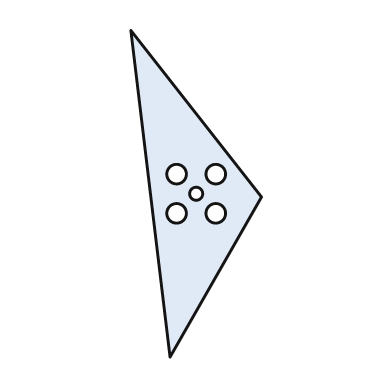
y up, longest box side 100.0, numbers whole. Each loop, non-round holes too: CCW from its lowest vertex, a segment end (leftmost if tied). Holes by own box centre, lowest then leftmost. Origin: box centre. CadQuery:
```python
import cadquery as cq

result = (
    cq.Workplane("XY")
    .moveTo(-8.0, -50.0)
    .lineTo(20.0, -1.0)
    .lineTo(-20.0, 50.0)
    .close()
    .moveTo(-6.0, -6.0)
    .circle(3.0)
    .moveTo(6.0, -6.0)
    .circle(3.0)
    .moveTo(0.0, 0.0)
    .circle(2.0)
    .moveTo(-6.0, 6.0)
    .circle(3.0)
    .moveTo(6.0, 6.0)
    .circle(3.0)
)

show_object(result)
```